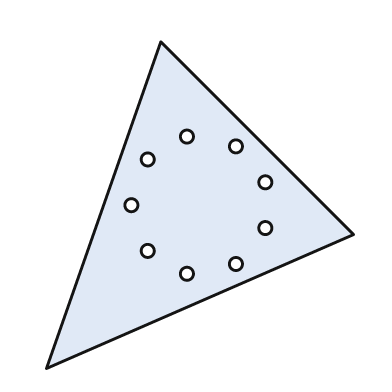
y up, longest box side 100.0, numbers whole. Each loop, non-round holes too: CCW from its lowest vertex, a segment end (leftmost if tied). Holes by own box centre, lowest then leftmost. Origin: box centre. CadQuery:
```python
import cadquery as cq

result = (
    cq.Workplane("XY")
    .moveTo(-47.0, -50.0)
    .lineTo(47.0, -9.0)
    .lineTo(-12.0, 50.0)
    .close()
    .moveTo(-4.0, -21.0)
    .circle(2.0)
    .moveTo(11.0, -18.0)
    .circle(2.0)
    .moveTo(-16.0, -14.0)
    .circle(2.0)
    .moveTo(20.0, -7.0)
    .circle(2.0)
    .moveTo(-21.0, 0.0)
    .circle(2.0)
    .moveTo(20.0, 7.0)
    .circle(2.0)
    .moveTo(-16.0, 14.0)
    .circle(2.0)
    .moveTo(11.0, 18.0)
    .circle(2.0)
    .moveTo(-4.0, 21.0)
    .circle(2.0)
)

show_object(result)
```